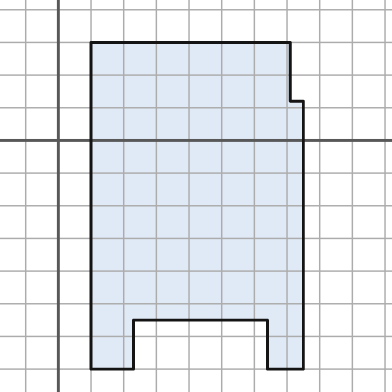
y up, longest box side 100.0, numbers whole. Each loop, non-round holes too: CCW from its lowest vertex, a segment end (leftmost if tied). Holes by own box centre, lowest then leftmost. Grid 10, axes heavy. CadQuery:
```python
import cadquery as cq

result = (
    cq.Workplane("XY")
    .moveTo(10.0, -70.0)
    .lineTo(23.0, -70.0)
    .lineTo(23.0, -55.0)
    .lineTo(64.0, -55.0)
    .lineTo(64.0, -70.0)
    .lineTo(75.0, -70.0)
    .lineTo(75.0, 12.0)
    .lineTo(71.0, 12.0)
    .lineTo(71.0, 30.0)
    .lineTo(10.0, 30.0)
    .close()
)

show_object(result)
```